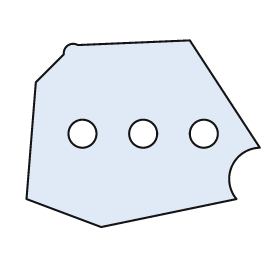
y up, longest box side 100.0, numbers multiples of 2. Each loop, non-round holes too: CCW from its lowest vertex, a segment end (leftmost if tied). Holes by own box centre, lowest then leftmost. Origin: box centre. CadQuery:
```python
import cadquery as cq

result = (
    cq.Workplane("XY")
    .moveTo(-18.0, -40.0)
    .lineTo(40.0, -28.0)
    .threePointArc((38.0, -14.0), (50.0, -6.0))
    .lineTo(20.0, 40.0)
    .lineTo(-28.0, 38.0)
    .threePointArc((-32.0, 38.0), (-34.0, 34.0))
    .lineTo(-46.0, 22.0)
    .lineTo(-50.0, -28.0)
    .close()
    .moveTo(-26.0, 0.0)
    .circle(6.0)
    .moveTo(0.0, 0.0)
    .circle(6.0)
    .moveTo(26.0, 0.0)
    .circle(6.0)
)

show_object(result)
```